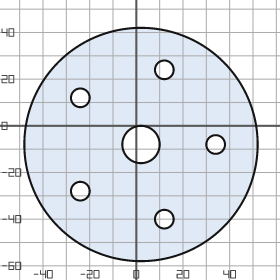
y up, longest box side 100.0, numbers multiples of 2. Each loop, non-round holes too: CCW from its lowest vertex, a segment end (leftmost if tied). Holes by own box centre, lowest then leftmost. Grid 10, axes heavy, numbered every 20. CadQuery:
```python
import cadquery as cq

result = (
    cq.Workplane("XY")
    .moveTo(2.0, -8.0)
    .circle(50.0)
    .moveTo(12.0, -40.0)
    .circle(4.0)
    .moveTo(-24.0, -28.0)
    .circle(4.0)
    .moveTo(2.0, -8.0)
    .circle(8.0)
    .moveTo(34.0, -8.0)
    .circle(4.0)
    .moveTo(-24.0, 12.0)
    .circle(4.0)
    .moveTo(12.0, 24.0)
    .circle(4.0)
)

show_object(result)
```